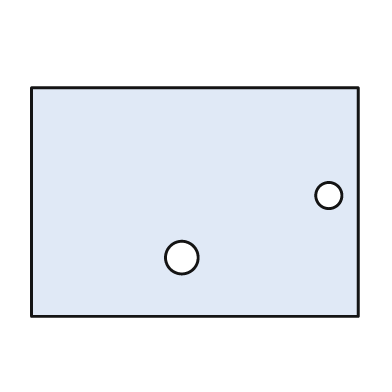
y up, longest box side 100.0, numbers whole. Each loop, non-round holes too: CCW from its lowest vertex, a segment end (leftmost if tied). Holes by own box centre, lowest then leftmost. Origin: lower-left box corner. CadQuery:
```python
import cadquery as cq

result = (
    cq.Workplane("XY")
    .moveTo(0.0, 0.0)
    .lineTo(100.0, 0.0)
    .lineTo(100.0, 70.0)
    .lineTo(0.0, 70.0)
    .close()
    .moveTo(46.0, 18.0)
    .circle(5.0)
    .moveTo(91.0, 37.0)
    .circle(4.0)
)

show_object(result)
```